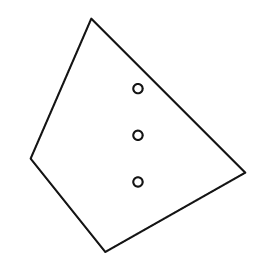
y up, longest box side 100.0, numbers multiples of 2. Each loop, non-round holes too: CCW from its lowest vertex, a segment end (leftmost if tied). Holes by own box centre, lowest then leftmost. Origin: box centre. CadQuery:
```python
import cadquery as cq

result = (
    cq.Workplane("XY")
    .moveTo(-14.0, -50.0)
    .lineTo(46.0, -16.0)
    .lineTo(-20.0, 50.0)
    .lineTo(-46.0, -10.0)
    .close()
    .moveTo(0.0, -20.0)
    .circle(2.0)
    .moveTo(0.0, 0.0)
    .circle(2.0)
    .moveTo(0.0, 20.0)
    .circle(2.0)
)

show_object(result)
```